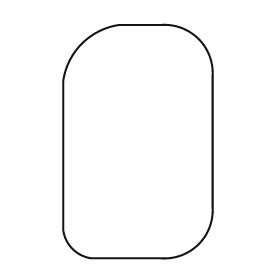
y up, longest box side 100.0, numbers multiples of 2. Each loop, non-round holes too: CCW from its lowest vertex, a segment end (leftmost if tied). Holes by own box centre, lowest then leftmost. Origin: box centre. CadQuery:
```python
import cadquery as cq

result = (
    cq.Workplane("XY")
    .moveTo(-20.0, -50.0)
    .lineTo(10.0, -50.0)
    .threePointArc((26.0, -44.0), (32.0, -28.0))
    .lineTo(32.0, 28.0)
    .threePointArc((26.0, 44.0), (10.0, 50.0))
    .lineTo(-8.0, 50.0)
    .threePointArc((-24.0, 42.0), (-32.0, 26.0))
    .lineTo(-32.0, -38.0)
    .threePointArc((-28.0, -46.0), (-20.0, -50.0))
    .close()
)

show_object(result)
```